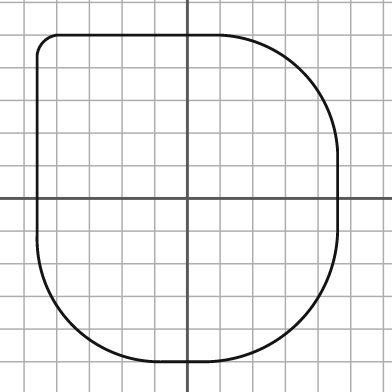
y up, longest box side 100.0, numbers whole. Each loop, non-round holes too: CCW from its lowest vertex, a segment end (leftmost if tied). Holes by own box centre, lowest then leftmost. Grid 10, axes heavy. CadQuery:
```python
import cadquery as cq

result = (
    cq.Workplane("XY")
    .moveTo(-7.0, -50.0)
    .lineTo(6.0, -50.0)
    .threePointArc((34.0, -38.0), (46.0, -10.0))
    .lineTo(46.0, 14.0)
    .threePointArc((35.0, 39.0), (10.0, 50.0))
    .lineTo(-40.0, 50.0)
    .threePointArc((-44.0, 48.0), (-46.0, 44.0))
    .lineTo(-46.0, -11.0)
    .threePointArc((-35.0, -39.0), (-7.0, -50.0))
    .close()
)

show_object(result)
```